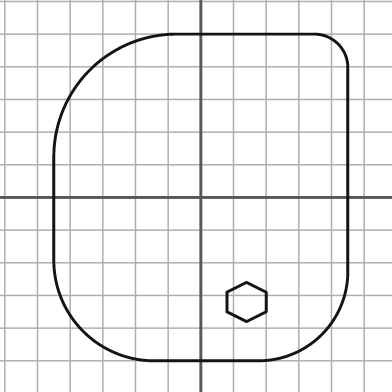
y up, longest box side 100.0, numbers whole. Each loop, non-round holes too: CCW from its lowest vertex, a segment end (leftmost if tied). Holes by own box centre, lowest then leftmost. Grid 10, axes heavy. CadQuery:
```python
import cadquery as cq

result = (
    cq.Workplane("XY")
    .moveTo(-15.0, -50.0)
    .lineTo(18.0, -50.0)
    .threePointArc((37.0, -42.0), (45.0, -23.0))
    .lineTo(45.0, 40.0)
    .threePointArc((42.0, 47.0), (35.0, 50.0))
    .lineTo(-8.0, 50.0)
    .threePointArc((-34.0, 39.0), (-45.0, 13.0))
    .lineTo(-45.0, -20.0)
    .threePointArc((-36.0, -41.0), (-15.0, -50.0))
    .close()
    .moveTo(14.0, -38.0)
    .lineTo(20.0, -35.0)
    .lineTo(20.0, -29.0)
    .lineTo(14.0, -26.0)
    .lineTo(8.0, -29.0)
    .lineTo(8.0, -35.0)
    .close()
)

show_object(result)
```